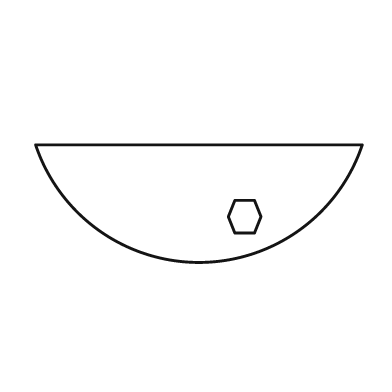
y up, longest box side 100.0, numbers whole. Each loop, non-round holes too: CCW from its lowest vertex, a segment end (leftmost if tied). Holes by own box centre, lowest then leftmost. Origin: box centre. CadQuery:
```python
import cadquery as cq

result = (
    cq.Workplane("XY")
    .moveTo(-50.0, 18.0)
    .threePointArc((0.0, -18.0), (50.0, 18.0))
    .close()
    .moveTo(11.0, -9.0)
    .lineTo(17.0, -9.0)
    .lineTo(19.0, -4.0)
    .lineTo(17.0, 1.0)
    .lineTo(11.0, 1.0)
    .lineTo(9.0, -4.0)
    .close()
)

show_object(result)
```